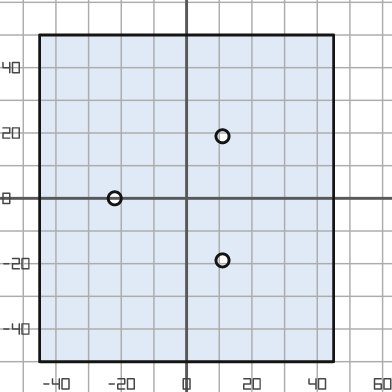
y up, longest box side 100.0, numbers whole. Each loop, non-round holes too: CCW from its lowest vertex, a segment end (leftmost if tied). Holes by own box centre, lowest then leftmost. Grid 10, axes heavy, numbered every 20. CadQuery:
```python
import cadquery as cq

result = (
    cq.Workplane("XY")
    .moveTo(-45.0, -50.0)
    .lineTo(45.0, -50.0)
    .lineTo(45.0, 50.0)
    .lineTo(-45.0, 50.0)
    .close()
    .moveTo(11.0, -19.0)
    .circle(2.0)
    .moveTo(-22.0, 0.0)
    .circle(2.0)
    .moveTo(11.0, 19.0)
    .circle(2.0)
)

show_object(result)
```